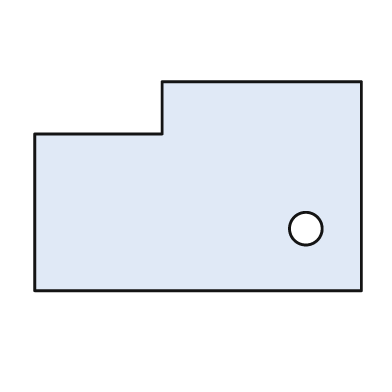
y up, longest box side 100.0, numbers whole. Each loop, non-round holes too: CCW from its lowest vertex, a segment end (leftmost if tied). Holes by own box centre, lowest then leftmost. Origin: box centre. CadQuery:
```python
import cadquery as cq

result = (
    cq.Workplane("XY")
    .moveTo(-50.0, -32.0)
    .lineTo(50.0, -32.0)
    .lineTo(50.0, 32.0)
    .lineTo(-11.0, 32.0)
    .lineTo(-11.0, 16.0)
    .lineTo(-50.0, 16.0)
    .close()
    .moveTo(33.0, -13.0)
    .circle(5.0)
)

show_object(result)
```